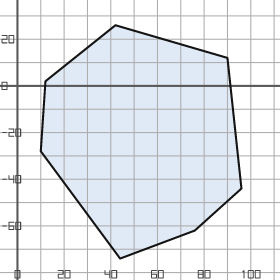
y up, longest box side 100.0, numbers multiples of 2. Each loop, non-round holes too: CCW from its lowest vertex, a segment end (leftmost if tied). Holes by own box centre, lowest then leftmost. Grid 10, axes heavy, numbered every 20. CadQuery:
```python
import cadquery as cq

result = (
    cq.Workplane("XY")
    .moveTo(44.0, -74.0)
    .lineTo(76.0, -62.0)
    .lineTo(96.0, -44.0)
    .lineTo(90.0, 12.0)
    .lineTo(42.0, 26.0)
    .lineTo(12.0, 2.0)
    .lineTo(10.0, -28.0)
    .close()
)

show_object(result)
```